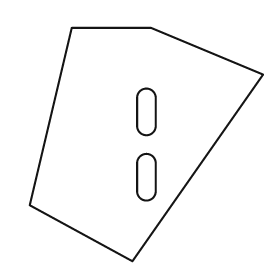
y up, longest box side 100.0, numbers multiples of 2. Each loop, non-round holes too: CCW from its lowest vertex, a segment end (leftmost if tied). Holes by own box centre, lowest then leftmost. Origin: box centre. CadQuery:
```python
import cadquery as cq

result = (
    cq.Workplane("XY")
    .moveTo(-6.0, -50.0)
    .lineTo(50.0, 30.0)
    .lineTo(2.0, 50.0)
    .lineTo(-32.0, 50.0)
    .lineTo(-50.0, -26.0)
    .close()
    .moveTo(-4.0, -20.0)
    .threePointArc((0.0, -24.0), (4.0, -20.0))
    .lineTo(4.0, -8.0)
    .threePointArc((0.0, -4.0), (-4.0, -8.0))
    .close()
    .moveTo(-4.0, 8.0)
    .threePointArc((0.0, 4.0), (4.0, 8.0))
    .lineTo(4.0, 20.0)
    .threePointArc((0.0, 24.0), (-4.0, 20.0))
    .close()
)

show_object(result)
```